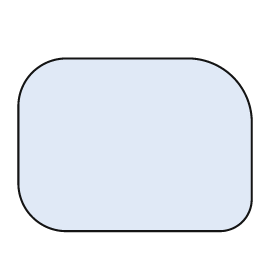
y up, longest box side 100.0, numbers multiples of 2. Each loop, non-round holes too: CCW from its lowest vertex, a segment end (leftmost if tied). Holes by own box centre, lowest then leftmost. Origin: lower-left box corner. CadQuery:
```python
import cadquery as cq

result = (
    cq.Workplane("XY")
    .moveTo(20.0, 0.0)
    .lineTo(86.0, 0.0)
    .threePointArc((96.0, 4.0), (100.0, 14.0))
    .lineTo(100.0, 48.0)
    .threePointArc((92.0, 66.0), (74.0, 74.0))
    .lineTo(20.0, 74.0)
    .threePointArc((6.0, 68.0), (0.0, 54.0))
    .lineTo(0.0, 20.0)
    .threePointArc((6.0, 6.0), (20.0, 0.0))
    .close()
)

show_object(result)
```